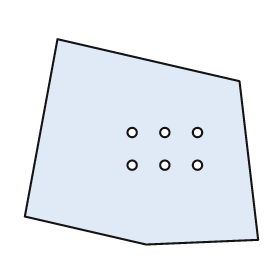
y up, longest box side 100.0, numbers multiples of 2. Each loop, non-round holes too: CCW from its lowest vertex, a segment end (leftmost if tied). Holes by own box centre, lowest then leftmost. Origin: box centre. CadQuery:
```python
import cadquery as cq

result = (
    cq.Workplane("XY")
    .moveTo(2.0, -44.0)
    .lineTo(50.0, -42.0)
    .lineTo(42.0, 26.0)
    .lineTo(-36.0, 44.0)
    .lineTo(-50.0, -32.0)
    .close()
    .moveTo(-4.0, -10.0)
    .circle(2.0)
    .moveTo(10.0, -10.0)
    .circle(2.0)
    .moveTo(24.0, -10.0)
    .circle(2.0)
    .moveTo(-4.0, 4.0)
    .circle(2.0)
    .moveTo(10.0, 4.0)
    .circle(2.0)
    .moveTo(24.0, 4.0)
    .circle(2.0)
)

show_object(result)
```